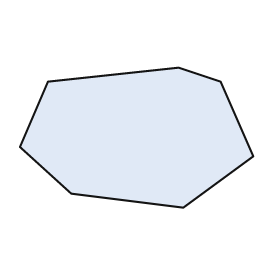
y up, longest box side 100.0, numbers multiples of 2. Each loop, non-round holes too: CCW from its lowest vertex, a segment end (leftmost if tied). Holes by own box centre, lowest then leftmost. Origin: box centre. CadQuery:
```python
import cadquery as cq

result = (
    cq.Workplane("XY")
    .moveTo(20.0, -30.0)
    .lineTo(50.0, -8.0)
    .lineTo(36.0, 24.0)
    .lineTo(18.0, 30.0)
    .lineTo(-38.0, 24.0)
    .lineTo(-50.0, -4.0)
    .lineTo(-28.0, -24.0)
    .close()
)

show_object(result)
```